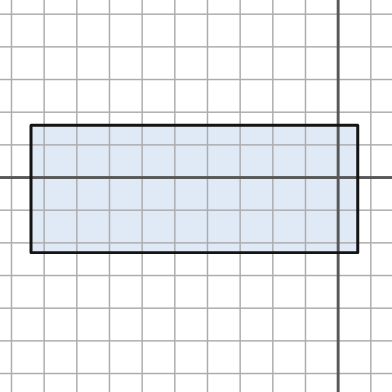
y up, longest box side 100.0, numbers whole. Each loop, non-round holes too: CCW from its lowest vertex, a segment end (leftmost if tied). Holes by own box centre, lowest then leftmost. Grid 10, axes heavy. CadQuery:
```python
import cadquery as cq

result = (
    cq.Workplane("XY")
    .moveTo(-94.0, -23.0)
    .lineTo(6.0, -23.0)
    .lineTo(6.0, 16.0)
    .lineTo(-94.0, 16.0)
    .close()
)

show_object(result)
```